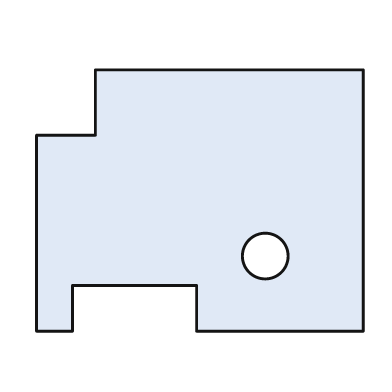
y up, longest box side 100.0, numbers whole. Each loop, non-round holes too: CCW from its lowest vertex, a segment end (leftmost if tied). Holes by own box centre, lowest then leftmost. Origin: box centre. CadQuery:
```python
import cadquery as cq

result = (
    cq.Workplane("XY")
    .moveTo(-50.0, -40.0)
    .lineTo(-39.0, -40.0)
    .lineTo(-39.0, -26.0)
    .lineTo(-1.0, -26.0)
    .lineTo(-1.0, -40.0)
    .lineTo(50.0, -40.0)
    .lineTo(50.0, 40.0)
    .lineTo(-32.0, 40.0)
    .lineTo(-32.0, 20.0)
    .lineTo(-50.0, 20.0)
    .close()
    .moveTo(20.0, -17.0)
    .circle(7.0)
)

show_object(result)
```